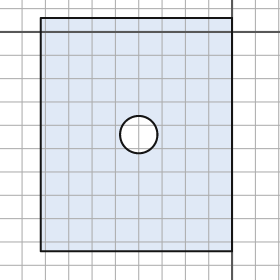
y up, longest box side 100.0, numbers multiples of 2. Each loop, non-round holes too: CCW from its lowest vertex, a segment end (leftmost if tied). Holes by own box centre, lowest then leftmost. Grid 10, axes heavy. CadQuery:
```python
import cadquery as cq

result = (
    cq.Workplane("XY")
    .moveTo(-82.0, -94.0)
    .lineTo(0.0, -94.0)
    .lineTo(0.0, 6.0)
    .lineTo(-82.0, 6.0)
    .close()
    .moveTo(-40.0, -44.0)
    .circle(8.0)
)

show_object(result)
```